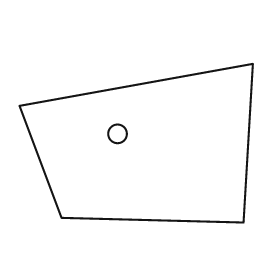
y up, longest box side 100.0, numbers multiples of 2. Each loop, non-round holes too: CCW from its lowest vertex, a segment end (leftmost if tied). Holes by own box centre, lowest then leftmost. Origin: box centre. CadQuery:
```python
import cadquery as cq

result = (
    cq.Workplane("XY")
    .moveTo(46.0, -34.0)
    .lineTo(50.0, 34.0)
    .lineTo(-50.0, 16.0)
    .lineTo(-32.0, -32.0)
    .close()
    .moveTo(-8.0, 4.0)
    .circle(4.0)
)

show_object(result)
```